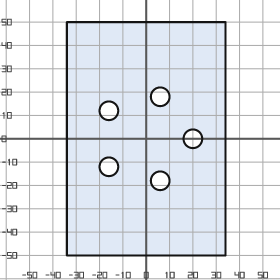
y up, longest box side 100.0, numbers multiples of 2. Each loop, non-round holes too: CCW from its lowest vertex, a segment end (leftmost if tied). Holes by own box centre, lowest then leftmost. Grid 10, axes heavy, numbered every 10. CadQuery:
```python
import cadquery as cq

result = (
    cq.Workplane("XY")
    .moveTo(-34.0, -50.0)
    .lineTo(34.0, -50.0)
    .lineTo(34.0, 50.0)
    .lineTo(-34.0, 50.0)
    .close()
    .moveTo(6.0, -18.0)
    .circle(4.0)
    .moveTo(-16.0, -12.0)
    .circle(4.0)
    .moveTo(20.0, 0.0)
    .circle(4.0)
    .moveTo(-16.0, 12.0)
    .circle(4.0)
    .moveTo(6.0, 18.0)
    .circle(4.0)
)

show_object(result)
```